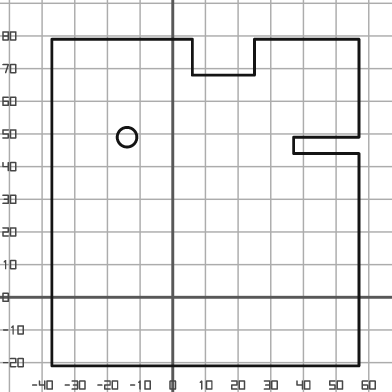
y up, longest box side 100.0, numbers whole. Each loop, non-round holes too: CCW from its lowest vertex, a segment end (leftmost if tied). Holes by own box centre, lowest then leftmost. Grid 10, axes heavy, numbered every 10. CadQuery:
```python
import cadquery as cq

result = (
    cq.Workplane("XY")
    .moveTo(-37.0, -21.0)
    .lineTo(57.0, -21.0)
    .lineTo(57.0, 44.0)
    .lineTo(37.0, 44.0)
    .lineTo(37.0, 49.0)
    .lineTo(57.0, 49.0)
    .lineTo(57.0, 79.0)
    .lineTo(25.0, 79.0)
    .lineTo(25.0, 68.0)
    .lineTo(6.0, 68.0)
    .lineTo(6.0, 79.0)
    .lineTo(-37.0, 79.0)
    .close()
    .moveTo(-14.0, 49.0)
    .circle(3.0)
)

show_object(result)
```